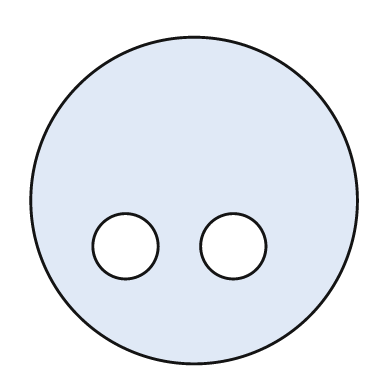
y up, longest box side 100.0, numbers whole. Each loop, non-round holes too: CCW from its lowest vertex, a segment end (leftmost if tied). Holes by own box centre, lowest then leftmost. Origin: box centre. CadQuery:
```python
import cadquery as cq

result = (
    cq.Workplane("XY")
    .moveTo(0.0, 0.0)
    .circle(50.0)
    .moveTo(-21.0, -14.0)
    .circle(10.0)
    .moveTo(12.0, -14.0)
    .circle(10.0)
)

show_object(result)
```